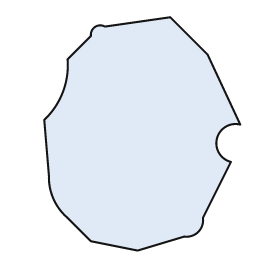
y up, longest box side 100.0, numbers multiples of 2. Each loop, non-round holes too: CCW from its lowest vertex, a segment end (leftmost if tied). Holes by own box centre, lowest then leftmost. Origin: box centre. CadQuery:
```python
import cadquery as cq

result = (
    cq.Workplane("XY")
    .moveTo(-2.0, -50.0)
    .lineTo(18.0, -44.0)
    .threePointArc((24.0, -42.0), (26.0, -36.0))
    .lineTo(38.0, -12.0)
    .threePointArc((32.0, -2.0), (42.0, 4.0))
    .lineTo(28.0, 34.0)
    .lineTo(12.0, 50.0)
    .lineTo(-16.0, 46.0)
    .threePointArc((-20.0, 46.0), (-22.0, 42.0))
    .lineTo(-32.0, 32.0)
    .threePointArc((-34.0, 18.0), (-42.0, 6.0))
    .lineTo(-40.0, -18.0)
    .threePointArc((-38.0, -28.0), (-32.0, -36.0))
    .lineTo(-22.0, -46.0)
    .close()
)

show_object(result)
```